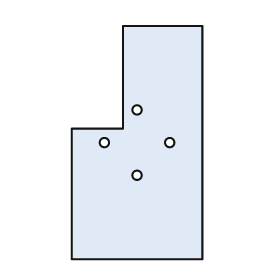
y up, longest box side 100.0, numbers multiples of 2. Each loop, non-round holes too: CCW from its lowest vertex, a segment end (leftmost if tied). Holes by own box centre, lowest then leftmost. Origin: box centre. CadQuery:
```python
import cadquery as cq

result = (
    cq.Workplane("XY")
    .moveTo(-28.0, -50.0)
    .lineTo(28.0, -50.0)
    .lineTo(28.0, 50.0)
    .lineTo(-6.0, 50.0)
    .lineTo(-6.0, 6.0)
    .lineTo(-28.0, 6.0)
    .close()
    .moveTo(0.0, -14.0)
    .circle(2.0)
    .moveTo(-14.0, 0.0)
    .circle(2.0)
    .moveTo(14.0, 0.0)
    .circle(2.0)
    .moveTo(0.0, 14.0)
    .circle(2.0)
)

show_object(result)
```